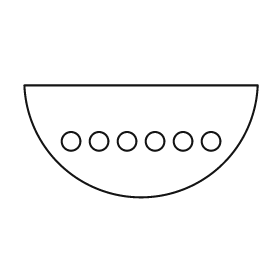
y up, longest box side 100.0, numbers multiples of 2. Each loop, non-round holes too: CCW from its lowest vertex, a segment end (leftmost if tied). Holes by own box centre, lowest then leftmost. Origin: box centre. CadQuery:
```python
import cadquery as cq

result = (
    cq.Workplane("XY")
    .moveTo(-50.0, 24.0)
    .threePointArc((0.0, -24.0), (50.0, 24.0))
    .close()
    .moveTo(-30.0, 0.0)
    .circle(4.0)
    .moveTo(-18.0, 0.0)
    .circle(4.0)
    .moveTo(-6.0, 0.0)
    .circle(4.0)
    .moveTo(6.0, 0.0)
    .circle(4.0)
    .moveTo(18.0, 0.0)
    .circle(4.0)
    .moveTo(30.0, 0.0)
    .circle(4.0)
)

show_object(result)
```